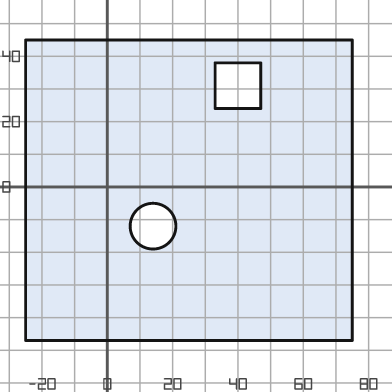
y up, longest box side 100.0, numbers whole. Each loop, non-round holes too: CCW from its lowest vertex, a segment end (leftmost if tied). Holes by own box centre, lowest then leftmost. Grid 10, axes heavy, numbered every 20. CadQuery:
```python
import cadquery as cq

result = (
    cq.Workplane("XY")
    .moveTo(-25.0, -47.0)
    .lineTo(75.0, -47.0)
    .lineTo(75.0, 45.0)
    .lineTo(-25.0, 45.0)
    .close()
    .moveTo(14.0, -12.0)
    .circle(7.0)
    .moveTo(33.0, 24.0)
    .lineTo(47.0, 24.0)
    .lineTo(47.0, 38.0)
    .lineTo(33.0, 38.0)
    .close()
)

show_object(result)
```